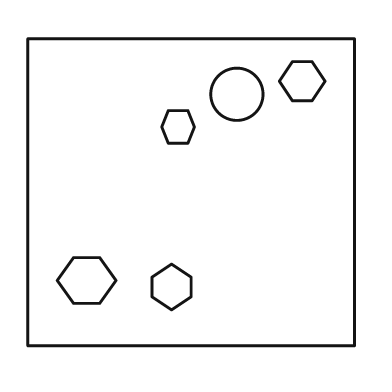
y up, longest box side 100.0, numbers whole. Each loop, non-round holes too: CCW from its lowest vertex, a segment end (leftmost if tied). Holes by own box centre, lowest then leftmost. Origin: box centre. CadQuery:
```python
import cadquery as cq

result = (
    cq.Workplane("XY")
    .moveTo(-50.0, -47.0)
    .lineTo(50.0, -47.0)
    .lineTo(50.0, 47.0)
    .lineTo(-50.0, 47.0)
    .close()
    .moveTo(-6.0, -36.0)
    .lineTo(0.0, -32.0)
    .lineTo(0.0, -26.0)
    .lineTo(-6.0, -22.0)
    .lineTo(-12.0, -26.0)
    .lineTo(-12.0, -32.0)
    .close()
    .moveTo(-36.0, -34.0)
    .lineTo(-28.0, -34.0)
    .lineTo(-23.0, -27.0)
    .lineTo(-28.0, -20.0)
    .lineTo(-36.0, -20.0)
    .lineTo(-41.0, -27.0)
    .close()
    .moveTo(-7.0, 15.0)
    .lineTo(-1.0, 15.0)
    .lineTo(1.0, 20.0)
    .lineTo(-1.0, 25.0)
    .lineTo(-7.0, 25.0)
    .lineTo(-9.0, 20.0)
    .close()
    .moveTo(14.0, 30.0)
    .circle(8.0)
    .moveTo(31.0, 28.0)
    .lineTo(37.0, 28.0)
    .lineTo(41.0, 34.0)
    .lineTo(37.0, 40.0)
    .lineTo(31.0, 40.0)
    .lineTo(27.0, 34.0)
    .close()
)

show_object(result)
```